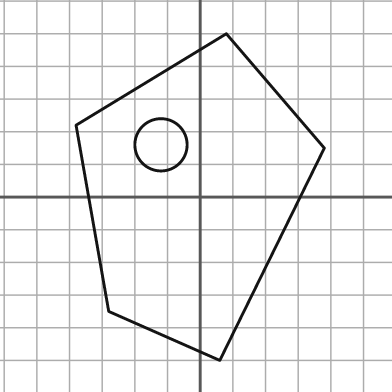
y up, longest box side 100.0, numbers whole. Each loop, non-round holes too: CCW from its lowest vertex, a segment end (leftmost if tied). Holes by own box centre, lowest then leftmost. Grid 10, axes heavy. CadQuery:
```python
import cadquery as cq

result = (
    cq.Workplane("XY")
    .moveTo(6.0, -50.0)
    .lineTo(38.0, 15.0)
    .lineTo(8.0, 50.0)
    .lineTo(-38.0, 22.0)
    .lineTo(-28.0, -35.0)
    .close()
    .moveTo(-12.0, 16.0)
    .circle(8.0)
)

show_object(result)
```